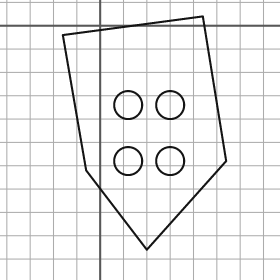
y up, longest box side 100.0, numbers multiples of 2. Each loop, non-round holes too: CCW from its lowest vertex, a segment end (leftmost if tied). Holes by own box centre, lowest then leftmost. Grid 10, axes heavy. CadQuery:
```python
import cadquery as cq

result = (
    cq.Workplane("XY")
    .moveTo(20.0, -96.0)
    .lineTo(54.0, -58.0)
    .lineTo(44.0, 4.0)
    .lineTo(-16.0, -4.0)
    .lineTo(-6.0, -62.0)
    .close()
    .moveTo(12.0, -58.0)
    .circle(6.0)
    .moveTo(30.0, -58.0)
    .circle(6.0)
    .moveTo(12.0, -34.0)
    .circle(6.0)
    .moveTo(30.0, -34.0)
    .circle(6.0)
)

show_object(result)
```